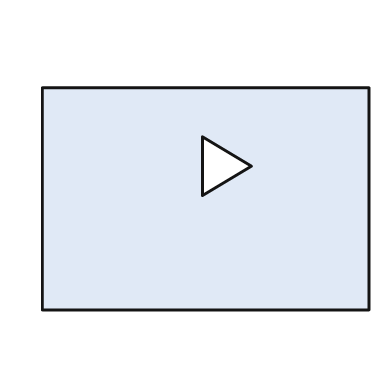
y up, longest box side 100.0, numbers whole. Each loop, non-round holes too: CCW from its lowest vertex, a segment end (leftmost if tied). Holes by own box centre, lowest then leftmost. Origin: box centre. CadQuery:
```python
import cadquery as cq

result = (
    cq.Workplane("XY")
    .moveTo(-50.0, -34.0)
    .lineTo(50.0, -34.0)
    .lineTo(50.0, 34.0)
    .lineTo(-50.0, 34.0)
    .close()
    .moveTo(-1.0, 1.0)
    .lineTo(14.0, 10.0)
    .lineTo(-1.0, 19.0)
    .close()
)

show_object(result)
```